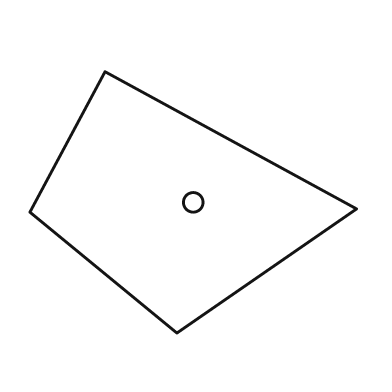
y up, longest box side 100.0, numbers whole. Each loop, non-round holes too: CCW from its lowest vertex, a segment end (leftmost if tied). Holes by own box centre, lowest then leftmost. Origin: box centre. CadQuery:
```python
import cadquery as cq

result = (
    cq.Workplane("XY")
    .moveTo(-5.0, -40.0)
    .lineTo(50.0, -2.0)
    .lineTo(-27.0, 40.0)
    .lineTo(-50.0, -3.0)
    .close()
    .moveTo(0.0, 0.0)
    .circle(3.0)
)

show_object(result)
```